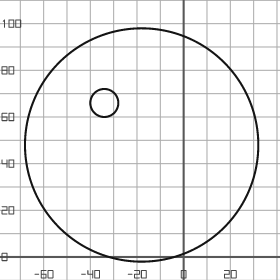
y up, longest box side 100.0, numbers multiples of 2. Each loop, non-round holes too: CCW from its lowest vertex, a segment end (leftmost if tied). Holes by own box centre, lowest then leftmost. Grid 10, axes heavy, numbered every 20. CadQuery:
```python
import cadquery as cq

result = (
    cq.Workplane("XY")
    .moveTo(-18.0, 48.0)
    .circle(50.0)
    .moveTo(-34.0, 66.0)
    .circle(6.0)
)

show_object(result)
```